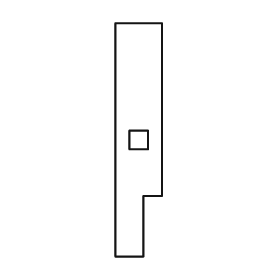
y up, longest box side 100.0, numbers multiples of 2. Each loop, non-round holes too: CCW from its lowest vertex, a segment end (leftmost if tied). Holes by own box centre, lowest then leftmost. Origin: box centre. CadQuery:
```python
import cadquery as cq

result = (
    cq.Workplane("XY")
    .moveTo(-10.0, -50.0)
    .lineTo(2.0, -50.0)
    .lineTo(2.0, -24.0)
    .lineTo(10.0, -24.0)
    .lineTo(10.0, 50.0)
    .lineTo(-10.0, 50.0)
    .close()
    .moveTo(-4.0, -4.0)
    .lineTo(4.0, -4.0)
    .lineTo(4.0, 4.0)
    .lineTo(-4.0, 4.0)
    .close()
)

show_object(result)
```